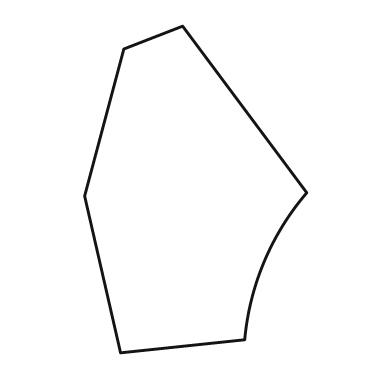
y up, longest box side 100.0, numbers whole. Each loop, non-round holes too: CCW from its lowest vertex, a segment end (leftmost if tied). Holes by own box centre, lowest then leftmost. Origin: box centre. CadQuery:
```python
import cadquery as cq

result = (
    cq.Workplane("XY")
    .moveTo(-23.0, -50.0)
    .lineTo(15.0, -46.0)
    .threePointArc((21.0, -22.0), (34.0, -1.0))
    .lineTo(-4.0, 50.0)
    .lineTo(-22.0, 43.0)
    .lineTo(-34.0, -2.0)
    .close()
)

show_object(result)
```